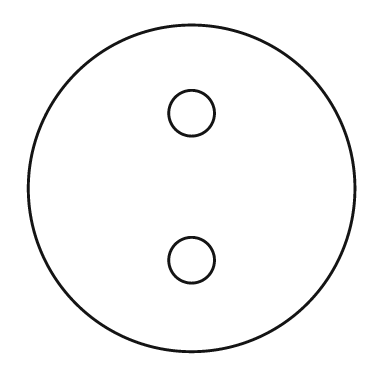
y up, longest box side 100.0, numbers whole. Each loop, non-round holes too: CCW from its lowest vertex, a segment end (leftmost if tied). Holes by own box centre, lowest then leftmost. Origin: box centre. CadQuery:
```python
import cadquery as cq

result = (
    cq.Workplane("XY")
    .moveTo(0.0, 0.0)
    .circle(50.0)
    .moveTo(0.0, -22.0)
    .circle(7.0)
    .moveTo(0.0, 23.0)
    .circle(7.0)
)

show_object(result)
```